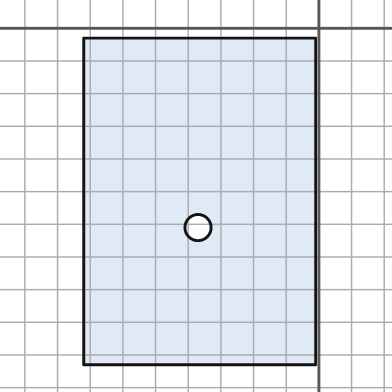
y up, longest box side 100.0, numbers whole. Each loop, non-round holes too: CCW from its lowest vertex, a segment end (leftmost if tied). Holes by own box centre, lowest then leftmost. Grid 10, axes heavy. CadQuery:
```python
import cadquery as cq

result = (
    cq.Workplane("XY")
    .moveTo(-72.0, -103.0)
    .lineTo(-1.0, -103.0)
    .lineTo(-1.0, -3.0)
    .lineTo(-72.0, -3.0)
    .close()
    .moveTo(-37.0, -61.0)
    .circle(4.0)
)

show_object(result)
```